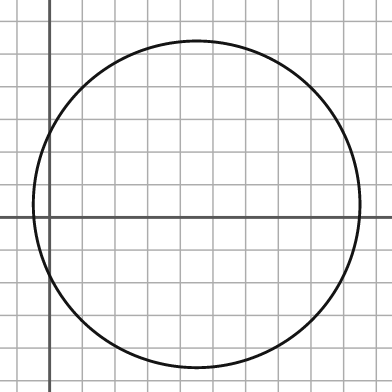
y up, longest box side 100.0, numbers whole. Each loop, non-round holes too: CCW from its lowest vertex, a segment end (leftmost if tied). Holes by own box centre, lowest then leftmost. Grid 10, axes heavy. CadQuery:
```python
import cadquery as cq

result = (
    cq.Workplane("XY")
    .moveTo(45.0, 4.0)
    .circle(50.0)
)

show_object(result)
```